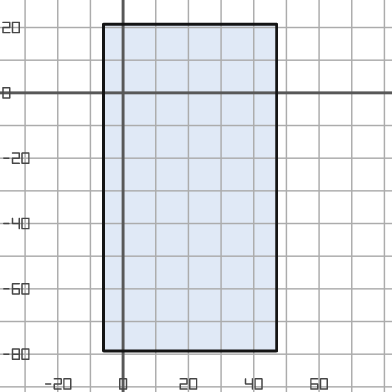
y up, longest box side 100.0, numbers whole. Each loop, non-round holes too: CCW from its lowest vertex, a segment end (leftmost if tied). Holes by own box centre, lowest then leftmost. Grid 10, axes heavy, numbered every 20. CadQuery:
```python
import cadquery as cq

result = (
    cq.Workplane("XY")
    .moveTo(-6.0, -79.0)
    .lineTo(47.0, -79.0)
    .lineTo(47.0, 21.0)
    .lineTo(-6.0, 21.0)
    .close()
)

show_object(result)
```